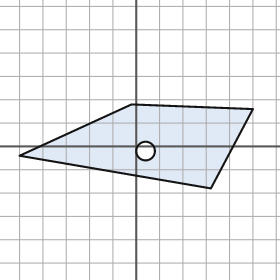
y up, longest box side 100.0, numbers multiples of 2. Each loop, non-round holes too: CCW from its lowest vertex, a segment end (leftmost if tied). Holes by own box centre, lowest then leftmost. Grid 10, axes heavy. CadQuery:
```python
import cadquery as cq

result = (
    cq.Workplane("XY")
    .moveTo(32.0, -18.0)
    .lineTo(50.0, 16.0)
    .lineTo(-2.0, 18.0)
    .lineTo(-50.0, -4.0)
    .close()
    .moveTo(4.0, -2.0)
    .circle(4.0)
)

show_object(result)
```